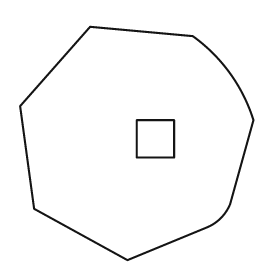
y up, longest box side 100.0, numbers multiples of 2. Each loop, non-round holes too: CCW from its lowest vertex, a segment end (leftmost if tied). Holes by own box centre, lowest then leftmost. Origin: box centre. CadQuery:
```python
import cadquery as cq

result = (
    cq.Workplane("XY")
    .moveTo(-4.0, -50.0)
    .lineTo(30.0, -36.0)
    .threePointArc((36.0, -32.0), (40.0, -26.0))
    .lineTo(50.0, 10.0)
    .threePointArc((40.0, 30.0), (24.0, 46.0))
    .lineTo(-20.0, 50.0)
    .lineTo(-50.0, 16.0)
    .lineTo(-44.0, -28.0)
    .close()
    .moveTo(0.0, -6.0)
    .lineTo(16.0, -6.0)
    .lineTo(16.0, 10.0)
    .lineTo(0.0, 10.0)
    .close()
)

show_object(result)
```